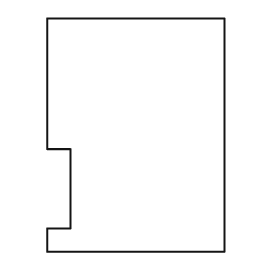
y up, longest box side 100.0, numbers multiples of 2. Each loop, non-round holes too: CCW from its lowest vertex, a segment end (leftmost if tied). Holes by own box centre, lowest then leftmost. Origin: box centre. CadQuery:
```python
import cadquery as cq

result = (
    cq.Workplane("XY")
    .moveTo(-38.0, -50.0)
    .lineTo(38.0, -50.0)
    .lineTo(38.0, 50.0)
    .lineTo(-38.0, 50.0)
    .lineTo(-38.0, -6.0)
    .lineTo(-28.0, -6.0)
    .lineTo(-28.0, -40.0)
    .lineTo(-38.0, -40.0)
    .close()
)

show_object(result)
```